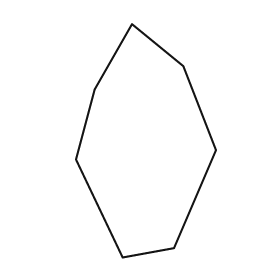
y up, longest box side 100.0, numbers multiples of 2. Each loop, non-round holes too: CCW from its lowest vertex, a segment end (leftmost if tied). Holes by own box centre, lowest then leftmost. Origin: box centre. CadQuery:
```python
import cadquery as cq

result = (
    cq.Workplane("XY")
    .moveTo(-10.0, -50.0)
    .lineTo(12.0, -46.0)
    .lineTo(30.0, -4.0)
    .lineTo(16.0, 32.0)
    .lineTo(-6.0, 50.0)
    .lineTo(-22.0, 22.0)
    .lineTo(-30.0, -8.0)
    .close()
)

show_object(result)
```